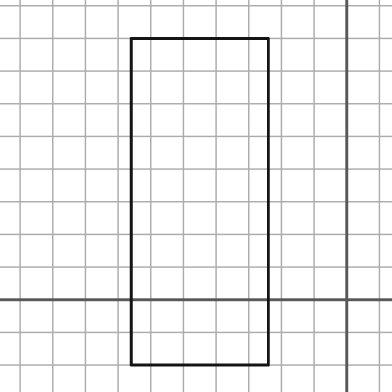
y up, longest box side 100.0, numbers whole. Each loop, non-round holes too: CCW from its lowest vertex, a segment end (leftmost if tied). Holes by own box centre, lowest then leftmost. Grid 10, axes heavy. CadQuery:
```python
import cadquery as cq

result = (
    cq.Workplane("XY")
    .moveTo(-66.0, -20.0)
    .lineTo(-24.0, -20.0)
    .lineTo(-24.0, 80.0)
    .lineTo(-66.0, 80.0)
    .close()
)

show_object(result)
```